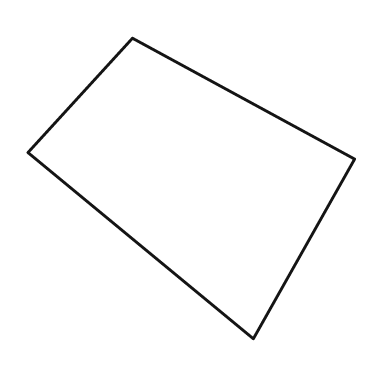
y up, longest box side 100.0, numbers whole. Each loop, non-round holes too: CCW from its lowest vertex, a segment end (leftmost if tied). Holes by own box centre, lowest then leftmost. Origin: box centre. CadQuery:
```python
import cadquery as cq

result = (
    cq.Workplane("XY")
    .moveTo(19.0, -46.0)
    .lineTo(50.0, 9.0)
    .lineTo(-18.0, 46.0)
    .lineTo(-50.0, 11.0)
    .close()
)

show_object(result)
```